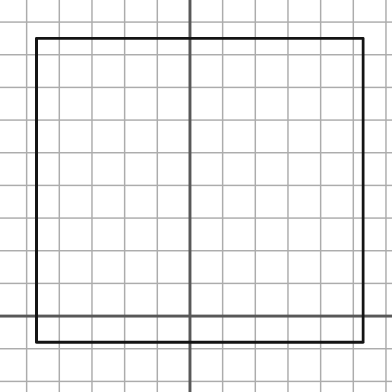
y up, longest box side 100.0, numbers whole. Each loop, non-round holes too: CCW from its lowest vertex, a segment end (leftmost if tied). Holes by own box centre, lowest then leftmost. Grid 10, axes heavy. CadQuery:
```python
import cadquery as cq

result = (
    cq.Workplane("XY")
    .moveTo(-47.0, -8.0)
    .lineTo(53.0, -8.0)
    .lineTo(53.0, 85.0)
    .lineTo(-47.0, 85.0)
    .close()
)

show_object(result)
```